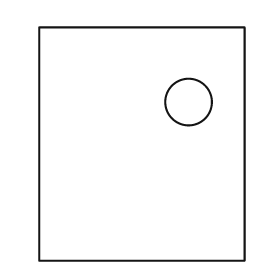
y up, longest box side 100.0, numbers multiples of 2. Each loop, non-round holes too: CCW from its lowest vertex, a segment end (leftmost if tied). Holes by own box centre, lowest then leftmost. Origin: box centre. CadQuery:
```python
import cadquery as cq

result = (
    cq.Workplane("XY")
    .moveTo(-44.0, -50.0)
    .lineTo(44.0, -50.0)
    .lineTo(44.0, 50.0)
    .lineTo(-44.0, 50.0)
    .close()
    .moveTo(20.0, 18.0)
    .circle(10.0)
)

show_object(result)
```